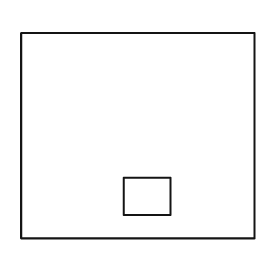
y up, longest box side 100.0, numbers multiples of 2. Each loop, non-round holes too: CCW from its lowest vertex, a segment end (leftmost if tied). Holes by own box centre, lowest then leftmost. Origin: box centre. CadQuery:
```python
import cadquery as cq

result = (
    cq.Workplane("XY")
    .moveTo(-50.0, -44.0)
    .lineTo(50.0, -44.0)
    .lineTo(50.0, 44.0)
    .lineTo(-50.0, 44.0)
    .close()
    .moveTo(-6.0, -34.0)
    .lineTo(14.0, -34.0)
    .lineTo(14.0, -18.0)
    .lineTo(-6.0, -18.0)
    .close()
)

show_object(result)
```